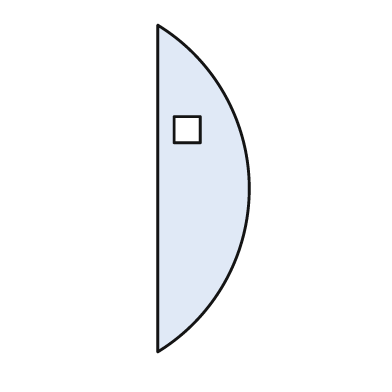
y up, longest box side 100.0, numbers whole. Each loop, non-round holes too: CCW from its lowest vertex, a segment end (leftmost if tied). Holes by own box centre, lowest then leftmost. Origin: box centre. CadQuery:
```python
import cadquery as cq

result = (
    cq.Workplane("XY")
    .moveTo(-14.0, -50.0)
    .threePointArc((14.0, 0.0), (-14.0, 50.0))
    .close()
    .moveTo(-9.0, 14.0)
    .lineTo(-1.0, 14.0)
    .lineTo(-1.0, 22.0)
    .lineTo(-9.0, 22.0)
    .close()
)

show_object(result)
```